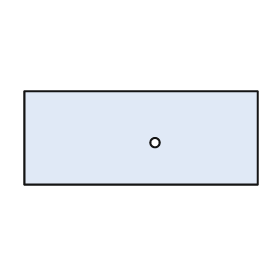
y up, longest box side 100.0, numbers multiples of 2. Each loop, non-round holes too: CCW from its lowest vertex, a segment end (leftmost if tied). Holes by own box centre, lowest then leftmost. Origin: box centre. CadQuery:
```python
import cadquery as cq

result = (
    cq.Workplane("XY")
    .moveTo(-50.0, -20.0)
    .lineTo(50.0, -20.0)
    .lineTo(50.0, 20.0)
    .lineTo(-50.0, 20.0)
    .close()
    .moveTo(6.0, -2.0)
    .circle(2.0)
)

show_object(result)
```